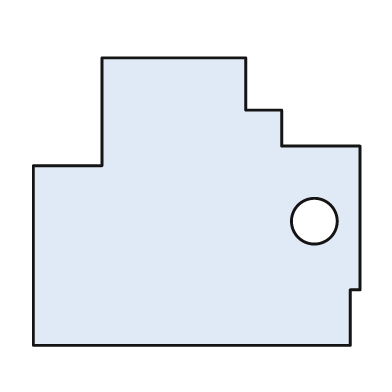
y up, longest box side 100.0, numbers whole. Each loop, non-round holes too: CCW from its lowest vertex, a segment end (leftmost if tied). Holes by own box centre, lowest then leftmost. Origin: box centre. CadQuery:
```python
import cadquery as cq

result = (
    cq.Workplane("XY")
    .moveTo(-50.0, -44.0)
    .lineTo(47.0, -44.0)
    .lineTo(47.0, -27.0)
    .lineTo(50.0, -27.0)
    .lineTo(50.0, 17.0)
    .lineTo(26.0, 17.0)
    .lineTo(26.0, 28.0)
    .lineTo(15.0, 28.0)
    .lineTo(15.0, 44.0)
    .lineTo(-29.0, 44.0)
    .lineTo(-29.0, 11.0)
    .lineTo(-50.0, 11.0)
    .close()
    .moveTo(36.0, -6.0)
    .circle(7.0)
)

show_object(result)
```